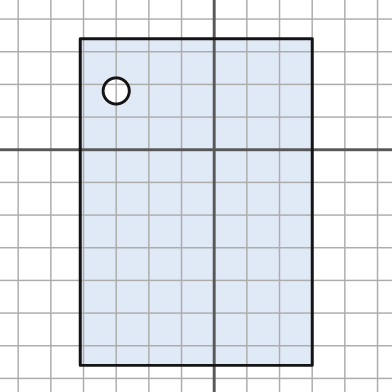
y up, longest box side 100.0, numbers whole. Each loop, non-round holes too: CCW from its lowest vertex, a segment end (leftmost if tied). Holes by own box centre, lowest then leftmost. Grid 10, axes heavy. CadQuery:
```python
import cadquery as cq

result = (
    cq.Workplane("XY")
    .moveTo(-41.0, -66.0)
    .lineTo(30.0, -66.0)
    .lineTo(30.0, 34.0)
    .lineTo(-41.0, 34.0)
    .close()
    .moveTo(-30.0, 18.0)
    .circle(4.0)
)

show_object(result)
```